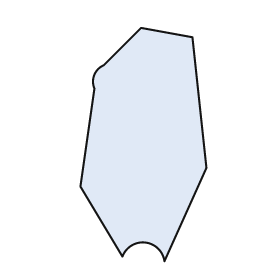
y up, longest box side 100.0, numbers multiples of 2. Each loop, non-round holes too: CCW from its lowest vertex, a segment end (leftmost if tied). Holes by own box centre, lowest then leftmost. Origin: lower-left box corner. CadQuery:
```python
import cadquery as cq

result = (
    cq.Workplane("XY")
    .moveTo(36.0, 0.0)
    .lineTo(54.0, 40.0)
    .lineTo(48.0, 96.0)
    .lineTo(26.0, 100.0)
    .lineTo(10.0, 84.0)
    .threePointArc((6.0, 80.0), (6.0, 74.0))
    .lineTo(0.0, 32.0)
    .lineTo(18.0, 2.0)
    .threePointArc((28.0, 8.0), (36.0, 0.0))
    .close()
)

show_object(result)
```